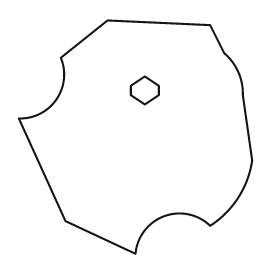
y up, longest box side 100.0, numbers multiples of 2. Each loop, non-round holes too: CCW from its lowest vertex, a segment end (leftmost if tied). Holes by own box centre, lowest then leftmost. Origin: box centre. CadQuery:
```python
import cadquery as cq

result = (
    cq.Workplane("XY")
    .moveTo(0.0, -50.0)
    .threePointArc((12.0, -34.0), (32.0, -38.0))
    .threePointArc((44.0, -26.0), (50.0, -10.0))
    .lineTo(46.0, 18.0)
    .threePointArc((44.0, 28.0), (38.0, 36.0))
    .lineTo(32.0, 48.0)
    .lineTo(-12.0, 50.0)
    .lineTo(-32.0, 34.0)
    .threePointArc((-34.0, 16.0), (-50.0, 8.0))
    .lineTo(-30.0, -36.0)
    .close()
    .moveTo(4.0, 14.0)
    .lineTo(10.0, 18.0)
    .lineTo(10.0, 22.0)
    .lineTo(4.0, 26.0)
    .lineTo(-2.0, 22.0)
    .lineTo(-2.0, 18.0)
    .close()
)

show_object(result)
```